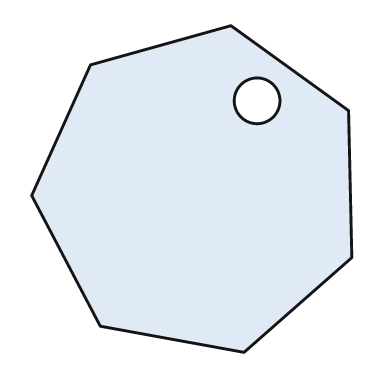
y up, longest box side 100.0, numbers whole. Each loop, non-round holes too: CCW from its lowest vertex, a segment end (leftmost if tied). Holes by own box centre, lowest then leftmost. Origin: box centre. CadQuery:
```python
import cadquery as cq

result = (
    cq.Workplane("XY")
    .moveTo(16.0, -50.0)
    .lineTo(49.0, -21.0)
    .lineTo(48.0, 24.0)
    .lineTo(12.0, 50.0)
    .lineTo(-31.0, 38.0)
    .lineTo(-49.0, -2.0)
    .lineTo(-28.0, -42.0)
    .close()
    .moveTo(20.0, 27.0)
    .circle(7.0)
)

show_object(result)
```